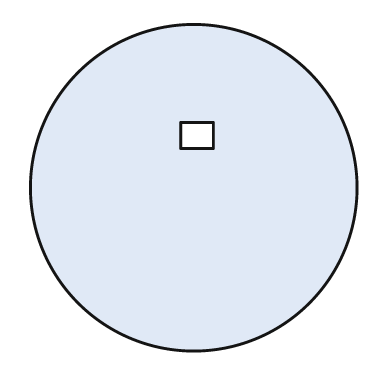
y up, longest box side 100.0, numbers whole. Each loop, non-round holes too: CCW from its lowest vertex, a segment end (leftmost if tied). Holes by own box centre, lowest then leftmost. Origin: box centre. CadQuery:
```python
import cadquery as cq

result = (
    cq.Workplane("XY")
    .moveTo(0.0, 0.0)
    .circle(50.0)
    .moveTo(-4.0, 12.0)
    .lineTo(6.0, 12.0)
    .lineTo(6.0, 20.0)
    .lineTo(-4.0, 20.0)
    .close()
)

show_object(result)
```